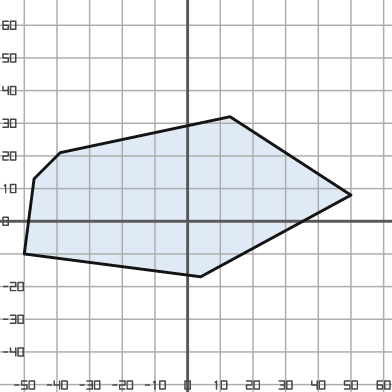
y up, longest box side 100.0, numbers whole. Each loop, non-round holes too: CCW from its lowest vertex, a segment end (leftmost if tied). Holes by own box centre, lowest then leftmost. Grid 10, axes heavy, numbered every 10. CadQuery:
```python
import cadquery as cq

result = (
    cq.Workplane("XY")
    .moveTo(4.0, -17.0)
    .lineTo(50.0, 8.0)
    .lineTo(13.0, 32.0)
    .lineTo(-39.0, 21.0)
    .lineTo(-47.0, 13.0)
    .lineTo(-50.0, -10.0)
    .close()
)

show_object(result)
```